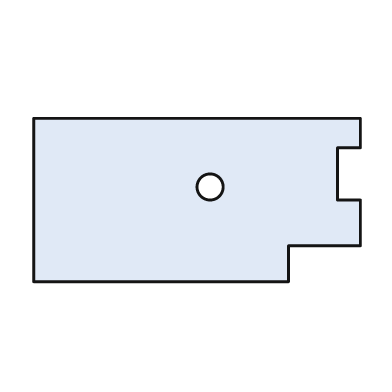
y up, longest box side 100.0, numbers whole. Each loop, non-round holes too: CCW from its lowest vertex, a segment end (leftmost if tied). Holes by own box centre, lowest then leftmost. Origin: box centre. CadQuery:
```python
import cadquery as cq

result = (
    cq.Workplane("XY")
    .moveTo(-50.0, -25.0)
    .lineTo(28.0, -25.0)
    .lineTo(28.0, -14.0)
    .lineTo(50.0, -14.0)
    .lineTo(50.0, 0.0)
    .lineTo(43.0, 0.0)
    .lineTo(43.0, 16.0)
    .lineTo(50.0, 16.0)
    .lineTo(50.0, 25.0)
    .lineTo(-50.0, 25.0)
    .close()
    .moveTo(4.0, 4.0)
    .circle(4.0)
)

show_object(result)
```